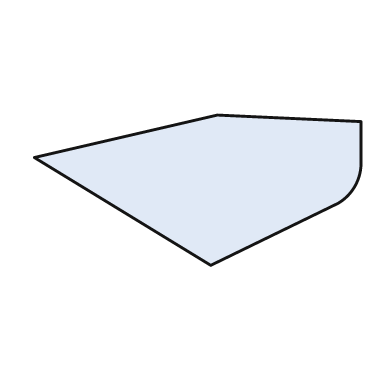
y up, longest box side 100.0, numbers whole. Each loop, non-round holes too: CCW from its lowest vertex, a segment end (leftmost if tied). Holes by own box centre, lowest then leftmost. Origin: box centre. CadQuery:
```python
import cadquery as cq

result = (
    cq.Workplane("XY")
    .moveTo(4.0, -23.0)
    .lineTo(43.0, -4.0)
    .threePointArc((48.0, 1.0), (50.0, 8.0))
    .lineTo(50.0, 21.0)
    .lineTo(6.0, 23.0)
    .lineTo(-50.0, 10.0)
    .close()
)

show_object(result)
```